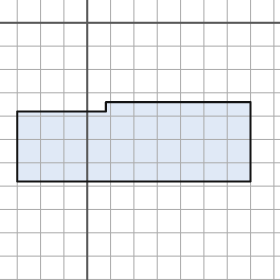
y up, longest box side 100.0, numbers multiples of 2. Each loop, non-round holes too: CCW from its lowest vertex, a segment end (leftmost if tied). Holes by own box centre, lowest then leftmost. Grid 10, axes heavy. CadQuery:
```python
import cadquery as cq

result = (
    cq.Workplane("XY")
    .moveTo(-30.0, -68.0)
    .lineTo(70.0, -68.0)
    .lineTo(70.0, -34.0)
    .lineTo(8.0, -34.0)
    .lineTo(8.0, -38.0)
    .lineTo(-30.0, -38.0)
    .close()
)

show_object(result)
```